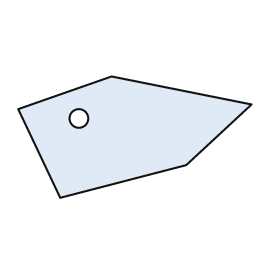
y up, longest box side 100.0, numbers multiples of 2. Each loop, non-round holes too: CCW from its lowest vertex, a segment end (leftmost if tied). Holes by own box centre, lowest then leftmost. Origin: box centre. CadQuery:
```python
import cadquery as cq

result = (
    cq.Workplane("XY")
    .moveTo(-32.0, -26.0)
    .lineTo(22.0, -12.0)
    .lineTo(50.0, 14.0)
    .lineTo(-10.0, 26.0)
    .lineTo(-50.0, 12.0)
    .close()
    .moveTo(-24.0, 8.0)
    .circle(4.0)
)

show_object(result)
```